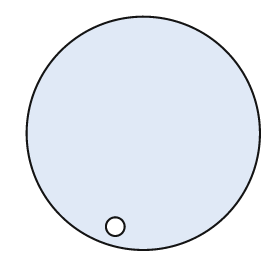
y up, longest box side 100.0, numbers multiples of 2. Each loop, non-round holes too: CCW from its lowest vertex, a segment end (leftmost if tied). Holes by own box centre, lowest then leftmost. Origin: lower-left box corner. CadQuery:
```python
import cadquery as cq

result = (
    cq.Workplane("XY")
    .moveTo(50.0, 50.0)
    .circle(50.0)
    .moveTo(38.0, 10.0)
    .circle(4.0)
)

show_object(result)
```